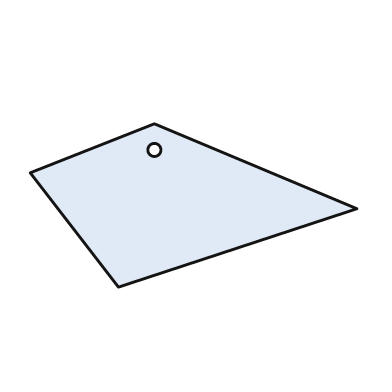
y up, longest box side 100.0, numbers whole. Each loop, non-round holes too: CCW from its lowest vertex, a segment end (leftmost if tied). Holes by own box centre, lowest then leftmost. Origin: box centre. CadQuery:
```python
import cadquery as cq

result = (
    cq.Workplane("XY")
    .moveTo(-23.0, -25.0)
    .lineTo(50.0, -1.0)
    .lineTo(-12.0, 25.0)
    .lineTo(-50.0, 10.0)
    .close()
    .moveTo(-12.0, 17.0)
    .circle(2.0)
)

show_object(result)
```